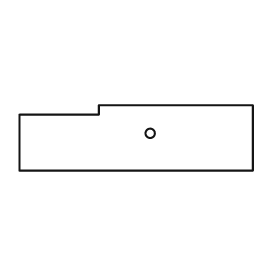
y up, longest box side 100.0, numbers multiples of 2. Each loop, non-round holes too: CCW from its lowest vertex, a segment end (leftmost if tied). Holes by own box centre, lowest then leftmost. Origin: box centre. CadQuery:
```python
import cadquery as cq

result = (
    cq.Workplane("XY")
    .moveTo(-50.0, -14.0)
    .lineTo(50.0, -14.0)
    .lineTo(50.0, 14.0)
    .lineTo(-16.0, 14.0)
    .lineTo(-16.0, 10.0)
    .lineTo(-50.0, 10.0)
    .close()
    .moveTo(6.0, 2.0)
    .circle(2.0)
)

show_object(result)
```